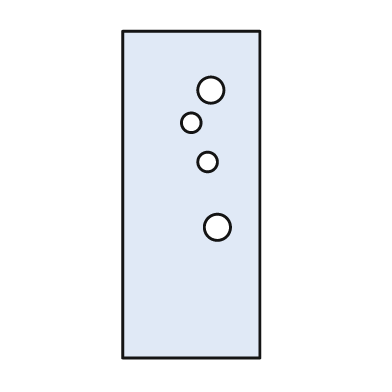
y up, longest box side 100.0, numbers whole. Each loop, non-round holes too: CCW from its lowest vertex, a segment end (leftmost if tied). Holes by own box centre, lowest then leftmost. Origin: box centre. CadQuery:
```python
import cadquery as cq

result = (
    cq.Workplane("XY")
    .moveTo(-21.0, -50.0)
    .lineTo(21.0, -50.0)
    .lineTo(21.0, 50.0)
    .lineTo(-21.0, 50.0)
    .close()
    .moveTo(8.0, -10.0)
    .circle(4.0)
    .moveTo(5.0, 10.0)
    .circle(3.0)
    .moveTo(0.0, 22.0)
    .circle(3.0)
    .moveTo(6.0, 32.0)
    .circle(4.0)
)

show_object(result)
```